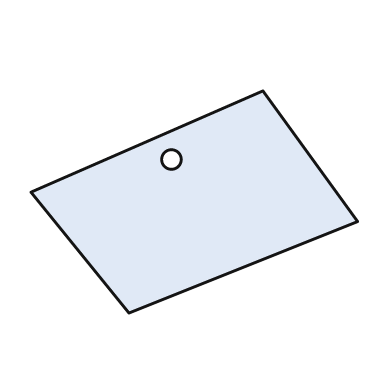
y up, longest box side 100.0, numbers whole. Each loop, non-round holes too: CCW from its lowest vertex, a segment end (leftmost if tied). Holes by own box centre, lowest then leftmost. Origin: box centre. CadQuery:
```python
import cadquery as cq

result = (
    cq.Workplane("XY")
    .moveTo(-20.0, -34.0)
    .lineTo(50.0, -6.0)
    .lineTo(21.0, 34.0)
    .lineTo(-50.0, 3.0)
    .close()
    .moveTo(-7.0, 13.0)
    .circle(3.0)
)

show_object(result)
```